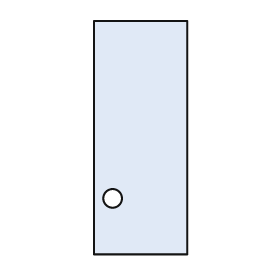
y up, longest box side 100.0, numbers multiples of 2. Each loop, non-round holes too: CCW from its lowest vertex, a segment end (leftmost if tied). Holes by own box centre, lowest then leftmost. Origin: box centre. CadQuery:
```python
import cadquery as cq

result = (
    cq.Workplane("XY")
    .moveTo(-20.0, -50.0)
    .lineTo(20.0, -50.0)
    .lineTo(20.0, 50.0)
    .lineTo(-20.0, 50.0)
    .close()
    .moveTo(-12.0, -26.0)
    .circle(4.0)
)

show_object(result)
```